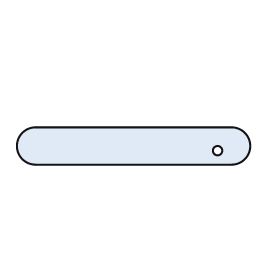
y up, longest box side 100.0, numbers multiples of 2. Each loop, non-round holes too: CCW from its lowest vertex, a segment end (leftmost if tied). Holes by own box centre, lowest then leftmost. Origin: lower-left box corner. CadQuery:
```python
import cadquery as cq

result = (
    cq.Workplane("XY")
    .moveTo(8.0, 0.0)
    .lineTo(92.0, 0.0)
    .threePointArc((100.0, 8.0), (92.0, 16.0))
    .lineTo(8.0, 16.0)
    .threePointArc((0.0, 8.0), (8.0, 0.0))
    .close()
    .moveTo(86.0, 6.0)
    .circle(2.0)
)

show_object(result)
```